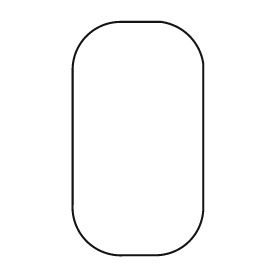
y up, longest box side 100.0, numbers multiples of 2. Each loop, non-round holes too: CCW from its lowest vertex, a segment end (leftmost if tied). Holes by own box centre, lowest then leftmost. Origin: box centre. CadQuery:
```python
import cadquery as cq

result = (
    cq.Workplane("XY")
    .moveTo(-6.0, -50.0)
    .lineTo(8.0, -50.0)
    .threePointArc((22.0, -44.0), (28.0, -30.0))
    .lineTo(28.0, 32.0)
    .threePointArc((22.0, 44.0), (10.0, 50.0))
    .lineTo(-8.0, 50.0)
    .threePointArc((-22.0, 44.0), (-28.0, 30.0))
    .lineTo(-28.0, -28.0)
    .threePointArc((-22.0, -44.0), (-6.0, -50.0))
    .close()
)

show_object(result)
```